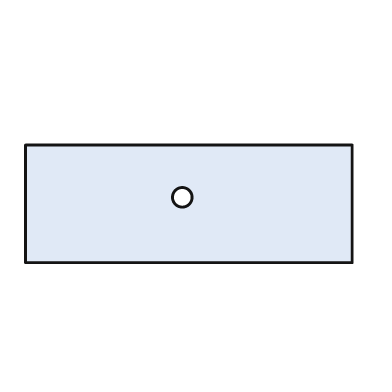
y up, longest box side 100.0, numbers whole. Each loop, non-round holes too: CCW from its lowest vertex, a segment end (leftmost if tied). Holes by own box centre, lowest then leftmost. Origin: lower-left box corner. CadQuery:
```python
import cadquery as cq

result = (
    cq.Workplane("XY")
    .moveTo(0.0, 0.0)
    .lineTo(100.0, 0.0)
    .lineTo(100.0, 36.0)
    .lineTo(0.0, 36.0)
    .close()
    .moveTo(48.0, 20.0)
    .circle(3.0)
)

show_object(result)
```